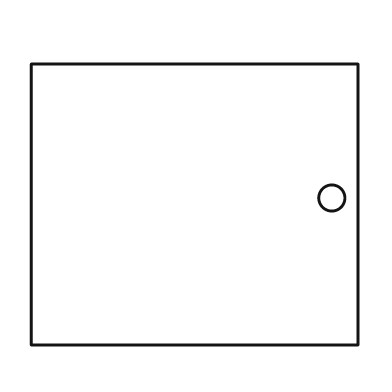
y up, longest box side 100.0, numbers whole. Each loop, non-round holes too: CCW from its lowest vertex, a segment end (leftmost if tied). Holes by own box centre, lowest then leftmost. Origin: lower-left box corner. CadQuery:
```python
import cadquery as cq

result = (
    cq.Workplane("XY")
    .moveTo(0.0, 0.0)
    .lineTo(100.0, 0.0)
    .lineTo(100.0, 86.0)
    .lineTo(0.0, 86.0)
    .close()
    .moveTo(92.0, 45.0)
    .circle(4.0)
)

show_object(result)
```